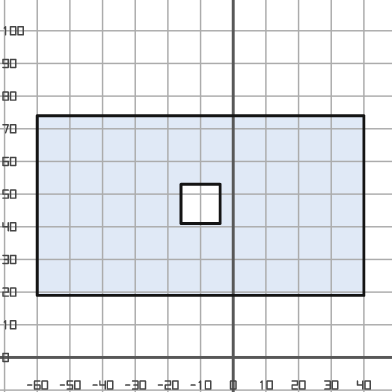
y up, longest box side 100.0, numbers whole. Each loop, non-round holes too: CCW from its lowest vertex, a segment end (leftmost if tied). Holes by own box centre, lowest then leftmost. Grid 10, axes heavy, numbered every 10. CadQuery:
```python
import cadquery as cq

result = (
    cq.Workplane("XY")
    .moveTo(-60.0, 19.0)
    .lineTo(40.0, 19.0)
    .lineTo(40.0, 74.0)
    .lineTo(-60.0, 74.0)
    .close()
    .moveTo(-16.0, 41.0)
    .lineTo(-4.0, 41.0)
    .lineTo(-4.0, 53.0)
    .lineTo(-16.0, 53.0)
    .close()
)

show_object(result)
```